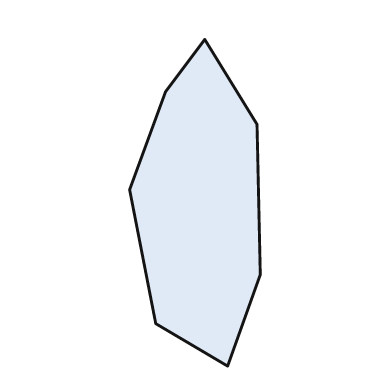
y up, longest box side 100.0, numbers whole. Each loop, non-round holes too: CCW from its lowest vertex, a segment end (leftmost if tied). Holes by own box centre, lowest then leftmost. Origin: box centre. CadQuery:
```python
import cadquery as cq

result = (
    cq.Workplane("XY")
    .moveTo(10.0, -50.0)
    .lineTo(20.0, -22.0)
    .lineTo(19.0, 24.0)
    .lineTo(3.0, 50.0)
    .lineTo(-9.0, 34.0)
    .lineTo(-20.0, 4.0)
    .lineTo(-12.0, -37.0)
    .close()
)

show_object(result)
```